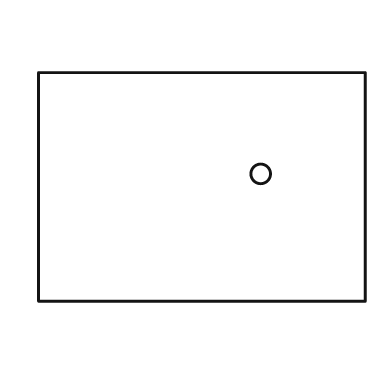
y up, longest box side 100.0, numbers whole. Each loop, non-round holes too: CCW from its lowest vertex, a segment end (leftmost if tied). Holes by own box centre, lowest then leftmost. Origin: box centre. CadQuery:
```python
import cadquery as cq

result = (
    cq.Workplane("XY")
    .moveTo(-50.0, -35.0)
    .lineTo(50.0, -35.0)
    .lineTo(50.0, 35.0)
    .lineTo(-50.0, 35.0)
    .close()
    .moveTo(18.0, 4.0)
    .circle(3.0)
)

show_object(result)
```